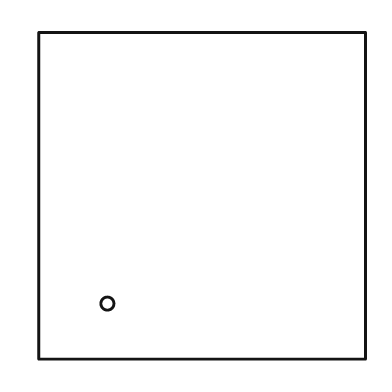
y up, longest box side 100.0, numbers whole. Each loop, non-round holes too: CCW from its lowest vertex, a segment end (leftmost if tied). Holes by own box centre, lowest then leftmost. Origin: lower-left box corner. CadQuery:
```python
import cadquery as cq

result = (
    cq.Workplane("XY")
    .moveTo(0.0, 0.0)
    .lineTo(100.0, 0.0)
    .lineTo(100.0, 100.0)
    .lineTo(0.0, 100.0)
    .close()
    .moveTo(21.0, 17.0)
    .circle(2.0)
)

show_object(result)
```